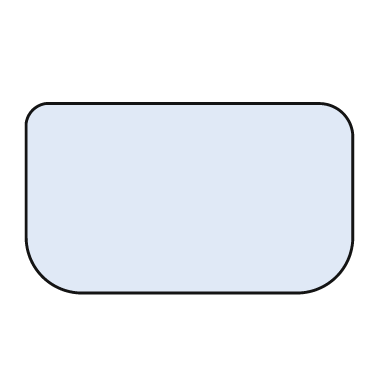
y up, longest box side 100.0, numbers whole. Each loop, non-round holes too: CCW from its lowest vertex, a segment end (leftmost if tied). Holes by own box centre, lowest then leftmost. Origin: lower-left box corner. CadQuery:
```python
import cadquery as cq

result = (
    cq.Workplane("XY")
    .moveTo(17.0, 0.0)
    .lineTo(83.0, 0.0)
    .threePointArc((95.0, 5.0), (100.0, 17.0))
    .lineTo(100.0, 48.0)
    .threePointArc((97.0, 55.0), (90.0, 58.0))
    .lineTo(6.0, 58.0)
    .threePointArc((2.0, 56.0), (0.0, 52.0))
    .lineTo(0.0, 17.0)
    .threePointArc((5.0, 5.0), (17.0, 0.0))
    .close()
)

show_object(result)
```